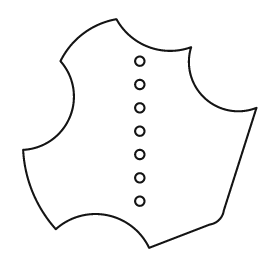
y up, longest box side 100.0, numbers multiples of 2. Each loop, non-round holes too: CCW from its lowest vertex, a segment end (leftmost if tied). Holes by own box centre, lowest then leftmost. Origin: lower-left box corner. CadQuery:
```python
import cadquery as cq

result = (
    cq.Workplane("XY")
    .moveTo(54.0, 0.0)
    .lineTo(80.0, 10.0)
    .threePointArc((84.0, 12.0), (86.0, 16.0))
    .lineTo(100.0, 60.0)
    .threePointArc((78.0, 64.0), (72.0, 86.0))
    .threePointArc((54.0, 86.0), (40.0, 98.0))
    .threePointArc((26.0, 92.0), (16.0, 80.0))
    .threePointArc((20.0, 56.0), (0.0, 42.0))
    .threePointArc((4.0, 24.0), (14.0, 8.0))
    .threePointArc((36.0, 14.0), (54.0, 0.0))
    .close()
    .moveTo(50.0, 20.0)
    .circle(2.0)
    .moveTo(50.0, 30.0)
    .circle(2.0)
    .moveTo(50.0, 40.0)
    .circle(2.0)
    .moveTo(50.0, 50.0)
    .circle(2.0)
    .moveTo(50.0, 60.0)
    .circle(2.0)
    .moveTo(50.0, 70.0)
    .circle(2.0)
    .moveTo(50.0, 80.0)
    .circle(2.0)
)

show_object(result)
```